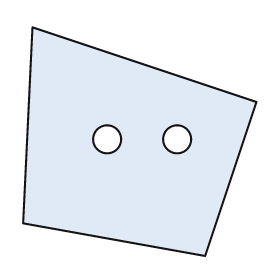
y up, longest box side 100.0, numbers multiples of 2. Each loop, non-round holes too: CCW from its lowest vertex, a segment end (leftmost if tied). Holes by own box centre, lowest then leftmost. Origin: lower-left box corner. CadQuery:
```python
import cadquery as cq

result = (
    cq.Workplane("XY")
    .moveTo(78.0, 0.0)
    .lineTo(100.0, 66.0)
    .lineTo(4.0, 98.0)
    .lineTo(0.0, 14.0)
    .close()
    .moveTo(36.0, 50.0)
    .circle(6.0)
    .moveTo(66.0, 50.0)
    .circle(6.0)
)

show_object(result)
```